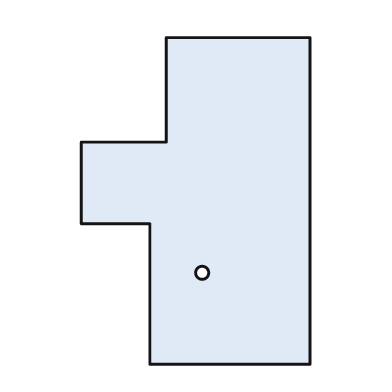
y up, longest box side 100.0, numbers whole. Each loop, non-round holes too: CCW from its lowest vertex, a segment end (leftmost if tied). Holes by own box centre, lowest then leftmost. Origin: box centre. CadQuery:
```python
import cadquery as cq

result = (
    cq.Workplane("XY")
    .moveTo(-14.0, -50.0)
    .lineTo(35.0, -50.0)
    .lineTo(35.0, 50.0)
    .lineTo(-9.0, 50.0)
    .lineTo(-9.0, 18.0)
    .lineTo(-35.0, 18.0)
    .lineTo(-35.0, -7.0)
    .lineTo(-14.0, -7.0)
    .close()
    .moveTo(2.0, -22.0)
    .circle(2.0)
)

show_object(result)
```